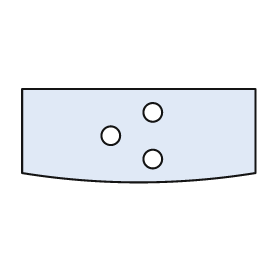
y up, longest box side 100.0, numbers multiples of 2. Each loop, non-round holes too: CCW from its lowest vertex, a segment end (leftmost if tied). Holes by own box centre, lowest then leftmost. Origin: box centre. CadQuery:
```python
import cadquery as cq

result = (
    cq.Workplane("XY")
    .moveTo(-50.0, -16.0)
    .threePointArc((0.0, -20.0), (50.0, -16.0))
    .lineTo(50.0, 20.0)
    .lineTo(-50.0, 20.0)
    .close()
    .moveTo(6.0, -10.0)
    .circle(4.0)
    .moveTo(-12.0, 0.0)
    .circle(4.0)
    .moveTo(6.0, 10.0)
    .circle(4.0)
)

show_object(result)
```